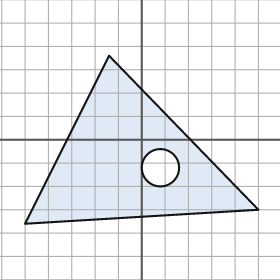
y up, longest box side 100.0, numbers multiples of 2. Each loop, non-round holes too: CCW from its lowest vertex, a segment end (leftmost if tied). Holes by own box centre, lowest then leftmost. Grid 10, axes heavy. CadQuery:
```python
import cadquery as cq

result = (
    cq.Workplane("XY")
    .moveTo(-50.0, -36.0)
    .lineTo(50.0, -30.0)
    .lineTo(-14.0, 36.0)
    .close()
    .moveTo(8.0, -12.0)
    .circle(8.0)
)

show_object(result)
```